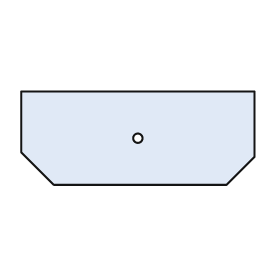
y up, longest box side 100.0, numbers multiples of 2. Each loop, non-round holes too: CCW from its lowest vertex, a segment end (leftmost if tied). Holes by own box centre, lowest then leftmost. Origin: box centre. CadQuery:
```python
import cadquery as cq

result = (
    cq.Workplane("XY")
    .moveTo(-36.0, -20.0)
    .lineTo(38.0, -20.0)
    .lineTo(50.0, -8.0)
    .lineTo(50.0, 20.0)
    .lineTo(-50.0, 20.0)
    .lineTo(-50.0, -6.0)
    .close()
    .moveTo(0.0, 0.0)
    .circle(2.0)
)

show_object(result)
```